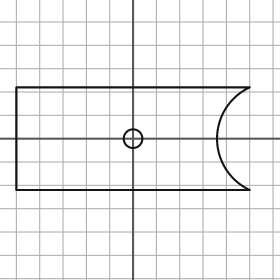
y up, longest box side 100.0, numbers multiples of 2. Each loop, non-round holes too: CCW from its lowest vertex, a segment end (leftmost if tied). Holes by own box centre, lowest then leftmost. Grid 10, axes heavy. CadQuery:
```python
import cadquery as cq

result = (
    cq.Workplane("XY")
    .moveTo(-50.0, -22.0)
    .lineTo(50.0, -22.0)
    .threePointArc((36.0, 0.0), (50.0, 22.0))
    .lineTo(-50.0, 22.0)
    .close()
    .moveTo(0.0, 0.0)
    .circle(4.0)
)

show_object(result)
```